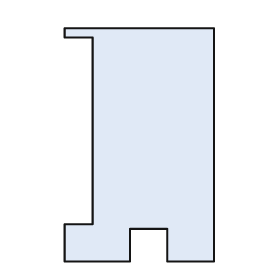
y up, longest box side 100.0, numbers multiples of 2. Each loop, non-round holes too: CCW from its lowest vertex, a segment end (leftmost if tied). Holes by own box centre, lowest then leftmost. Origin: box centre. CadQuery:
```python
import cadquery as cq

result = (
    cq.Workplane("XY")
    .moveTo(-32.0, -50.0)
    .lineTo(-4.0, -50.0)
    .lineTo(-4.0, -36.0)
    .lineTo(12.0, -36.0)
    .lineTo(12.0, -50.0)
    .lineTo(32.0, -50.0)
    .lineTo(32.0, 50.0)
    .lineTo(-32.0, 50.0)
    .lineTo(-32.0, 46.0)
    .lineTo(-20.0, 46.0)
    .lineTo(-20.0, -34.0)
    .lineTo(-32.0, -34.0)
    .close()
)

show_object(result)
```